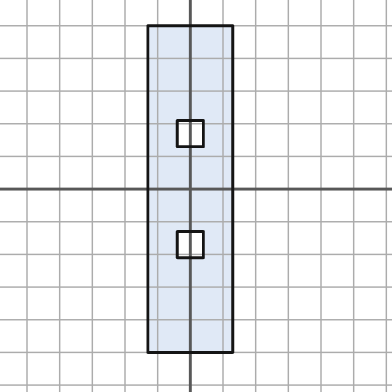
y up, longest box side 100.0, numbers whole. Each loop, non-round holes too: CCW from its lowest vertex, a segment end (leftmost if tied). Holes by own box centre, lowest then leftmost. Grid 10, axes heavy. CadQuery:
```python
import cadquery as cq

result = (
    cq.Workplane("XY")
    .moveTo(-13.0, -50.0)
    .lineTo(13.0, -50.0)
    .lineTo(13.0, 50.0)
    .lineTo(-13.0, 50.0)
    .close()
    .moveTo(-4.0, -21.0)
    .lineTo(4.0, -21.0)
    .lineTo(4.0, -13.0)
    .lineTo(-4.0, -13.0)
    .close()
    .moveTo(-4.0, 13.0)
    .lineTo(4.0, 13.0)
    .lineTo(4.0, 21.0)
    .lineTo(-4.0, 21.0)
    .close()
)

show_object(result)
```